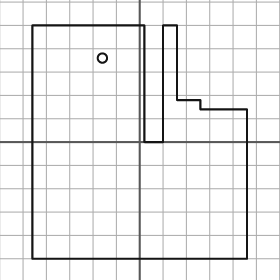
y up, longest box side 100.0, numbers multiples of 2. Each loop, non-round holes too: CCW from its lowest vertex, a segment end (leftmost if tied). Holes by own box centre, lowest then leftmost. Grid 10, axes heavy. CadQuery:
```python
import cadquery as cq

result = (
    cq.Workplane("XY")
    .moveTo(-46.0, -50.0)
    .lineTo(46.0, -50.0)
    .lineTo(46.0, 14.0)
    .lineTo(26.0, 14.0)
    .lineTo(26.0, 18.0)
    .lineTo(16.0, 18.0)
    .lineTo(16.0, 50.0)
    .lineTo(10.0, 50.0)
    .lineTo(10.0, 0.0)
    .lineTo(2.0, 0.0)
    .lineTo(2.0, 50.0)
    .lineTo(-46.0, 50.0)
    .close()
    .moveTo(-16.0, 36.0)
    .circle(2.0)
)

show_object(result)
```